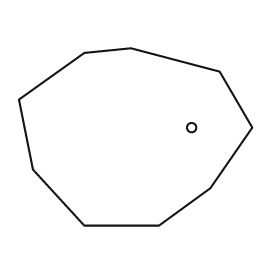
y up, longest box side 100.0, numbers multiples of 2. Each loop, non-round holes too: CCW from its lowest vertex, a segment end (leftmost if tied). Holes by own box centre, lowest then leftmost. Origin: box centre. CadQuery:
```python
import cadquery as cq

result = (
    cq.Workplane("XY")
    .moveTo(-22.0, -38.0)
    .lineTo(10.0, -38.0)
    .lineTo(32.0, -22.0)
    .lineTo(50.0, 4.0)
    .lineTo(36.0, 28.0)
    .lineTo(-2.0, 38.0)
    .lineTo(-22.0, 36.0)
    .lineTo(-50.0, 16.0)
    .lineTo(-44.0, -14.0)
    .close()
    .moveTo(24.0, 4.0)
    .circle(2.0)
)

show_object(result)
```